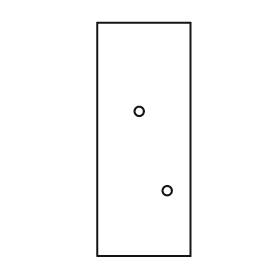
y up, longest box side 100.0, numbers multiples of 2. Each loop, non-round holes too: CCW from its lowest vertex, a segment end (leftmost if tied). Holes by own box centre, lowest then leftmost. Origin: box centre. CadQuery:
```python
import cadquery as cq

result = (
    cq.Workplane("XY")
    .moveTo(-20.0, -50.0)
    .lineTo(20.0, -50.0)
    .lineTo(20.0, 50.0)
    .lineTo(-20.0, 50.0)
    .close()
    .moveTo(10.0, -22.0)
    .circle(2.0)
    .moveTo(-2.0, 12.0)
    .circle(2.0)
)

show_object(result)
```